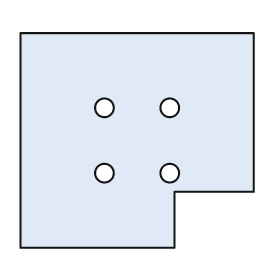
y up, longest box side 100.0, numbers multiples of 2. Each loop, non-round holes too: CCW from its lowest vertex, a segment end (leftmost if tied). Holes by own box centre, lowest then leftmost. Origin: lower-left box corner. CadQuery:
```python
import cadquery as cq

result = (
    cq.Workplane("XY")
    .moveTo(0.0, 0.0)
    .lineTo(66.0, 0.0)
    .lineTo(66.0, 24.0)
    .lineTo(100.0, 24.0)
    .lineTo(100.0, 92.0)
    .lineTo(0.0, 92.0)
    .close()
    .moveTo(36.0, 32.0)
    .circle(4.0)
    .moveTo(64.0, 32.0)
    .circle(4.0)
    .moveTo(36.0, 60.0)
    .circle(4.0)
    .moveTo(64.0, 60.0)
    .circle(4.0)
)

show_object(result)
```